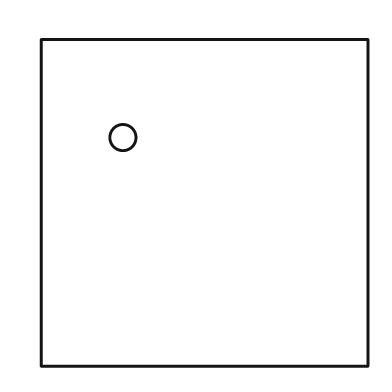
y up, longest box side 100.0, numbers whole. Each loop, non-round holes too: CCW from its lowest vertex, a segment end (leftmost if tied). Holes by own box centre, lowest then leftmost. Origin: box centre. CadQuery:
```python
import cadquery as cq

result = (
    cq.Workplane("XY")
    .moveTo(-50.0, -50.0)
    .lineTo(50.0, -50.0)
    .lineTo(50.0, 50.0)
    .lineTo(-50.0, 50.0)
    .close()
    .moveTo(-25.0, 20.0)
    .circle(4.0)
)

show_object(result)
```